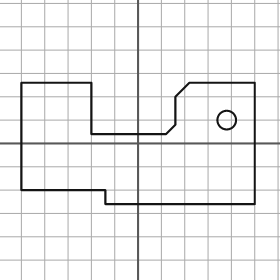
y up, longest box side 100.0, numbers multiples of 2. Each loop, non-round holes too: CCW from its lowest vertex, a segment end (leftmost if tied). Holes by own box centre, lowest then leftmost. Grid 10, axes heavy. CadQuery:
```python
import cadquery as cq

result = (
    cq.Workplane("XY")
    .moveTo(-14.0, -26.0)
    .lineTo(50.0, -26.0)
    .lineTo(50.0, 26.0)
    .lineTo(22.0, 26.0)
    .lineTo(16.0, 20.0)
    .lineTo(16.0, 8.0)
    .lineTo(12.0, 4.0)
    .lineTo(-20.0, 4.0)
    .lineTo(-20.0, 26.0)
    .lineTo(-50.0, 26.0)
    .lineTo(-50.0, -20.0)
    .lineTo(-14.0, -20.0)
    .close()
    .moveTo(38.0, 10.0)
    .circle(4.0)
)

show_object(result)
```